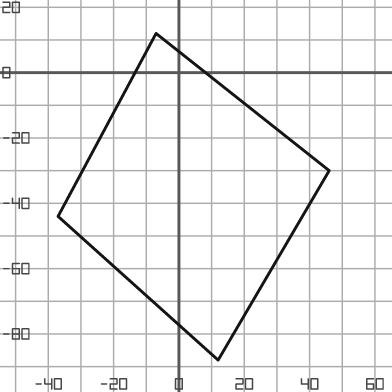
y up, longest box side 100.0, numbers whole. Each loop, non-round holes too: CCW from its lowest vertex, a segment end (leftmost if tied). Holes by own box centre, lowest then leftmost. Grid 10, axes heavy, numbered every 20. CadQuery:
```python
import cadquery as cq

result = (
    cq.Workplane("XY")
    .moveTo(12.0, -88.0)
    .lineTo(46.0, -30.0)
    .lineTo(-7.0, 12.0)
    .lineTo(-37.0, -44.0)
    .close()
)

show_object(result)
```